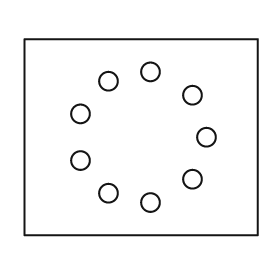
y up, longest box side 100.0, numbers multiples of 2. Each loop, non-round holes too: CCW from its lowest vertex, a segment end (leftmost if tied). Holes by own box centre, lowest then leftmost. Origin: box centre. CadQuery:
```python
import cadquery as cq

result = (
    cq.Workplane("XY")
    .moveTo(-50.0, -42.0)
    .lineTo(50.0, -42.0)
    .lineTo(50.0, 42.0)
    .lineTo(-50.0, 42.0)
    .close()
    .moveTo(4.0, -28.0)
    .circle(4.0)
    .moveTo(-14.0, -24.0)
    .circle(4.0)
    .moveTo(22.0, -18.0)
    .circle(4.0)
    .moveTo(-26.0, -10.0)
    .circle(4.0)
    .moveTo(28.0, 0.0)
    .circle(4.0)
    .moveTo(-26.0, 10.0)
    .circle(4.0)
    .moveTo(22.0, 18.0)
    .circle(4.0)
    .moveTo(-14.0, 24.0)
    .circle(4.0)
    .moveTo(4.0, 28.0)
    .circle(4.0)
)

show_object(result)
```